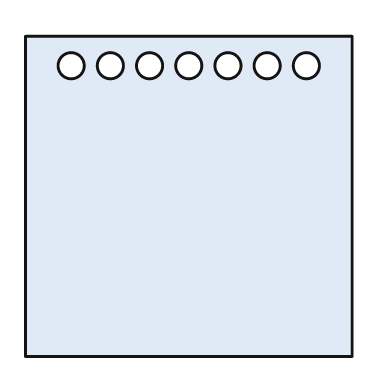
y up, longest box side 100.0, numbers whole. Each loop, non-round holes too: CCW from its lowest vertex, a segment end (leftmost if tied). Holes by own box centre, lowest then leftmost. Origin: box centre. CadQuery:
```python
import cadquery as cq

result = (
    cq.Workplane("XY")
    .moveTo(-50.0, -49.0)
    .lineTo(50.0, -49.0)
    .lineTo(50.0, 49.0)
    .lineTo(-50.0, 49.0)
    .close()
    .moveTo(-36.0, 40.0)
    .circle(4.0)
    .moveTo(-24.0, 40.0)
    .circle(4.0)
    .moveTo(-12.0, 40.0)
    .circle(4.0)
    .moveTo(0.0, 40.0)
    .circle(4.0)
    .moveTo(12.0, 40.0)
    .circle(4.0)
    .moveTo(24.0, 40.0)
    .circle(4.0)
    .moveTo(36.0, 40.0)
    .circle(4.0)
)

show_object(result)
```